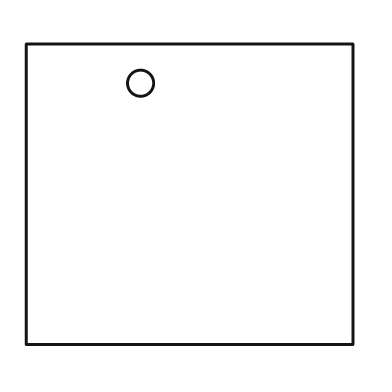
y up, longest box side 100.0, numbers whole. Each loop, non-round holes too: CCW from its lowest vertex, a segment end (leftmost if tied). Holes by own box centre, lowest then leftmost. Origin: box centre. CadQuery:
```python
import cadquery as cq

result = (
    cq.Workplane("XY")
    .moveTo(-50.0, -46.0)
    .lineTo(50.0, -46.0)
    .lineTo(50.0, 46.0)
    .lineTo(-50.0, 46.0)
    .close()
    .moveTo(-15.0, 34.0)
    .circle(4.0)
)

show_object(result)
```